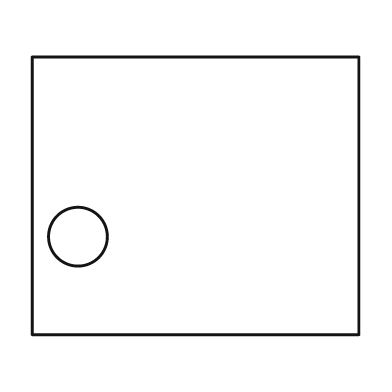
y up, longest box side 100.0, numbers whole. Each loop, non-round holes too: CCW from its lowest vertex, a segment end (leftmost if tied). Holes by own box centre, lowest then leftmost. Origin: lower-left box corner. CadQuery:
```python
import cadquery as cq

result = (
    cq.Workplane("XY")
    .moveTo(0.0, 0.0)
    .lineTo(100.0, 0.0)
    .lineTo(100.0, 85.0)
    .lineTo(0.0, 85.0)
    .close()
    .moveTo(14.0, 30.0)
    .circle(9.0)
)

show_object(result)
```